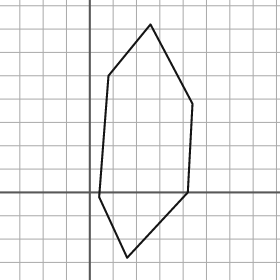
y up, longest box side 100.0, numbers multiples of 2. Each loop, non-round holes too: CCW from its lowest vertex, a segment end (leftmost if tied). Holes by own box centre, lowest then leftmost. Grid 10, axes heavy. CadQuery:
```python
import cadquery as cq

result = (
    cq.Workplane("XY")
    .moveTo(16.0, -28.0)
    .lineTo(42.0, 0.0)
    .lineTo(44.0, 38.0)
    .lineTo(26.0, 72.0)
    .lineTo(8.0, 50.0)
    .lineTo(4.0, -2.0)
    .close()
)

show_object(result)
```